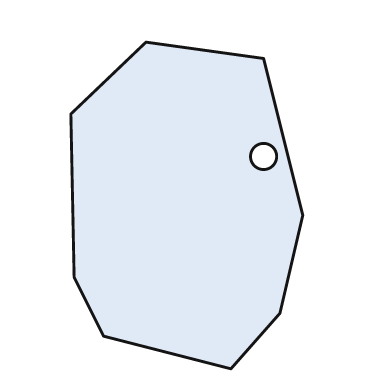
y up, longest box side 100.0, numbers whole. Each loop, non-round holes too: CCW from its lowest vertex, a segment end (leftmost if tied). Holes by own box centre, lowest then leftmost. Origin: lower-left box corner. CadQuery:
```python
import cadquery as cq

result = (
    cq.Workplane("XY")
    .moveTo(49.0, 0.0)
    .lineTo(64.0, 17.0)
    .lineTo(71.0, 47.0)
    .lineTo(59.0, 95.0)
    .lineTo(23.0, 100.0)
    .lineTo(0.0, 78.0)
    .lineTo(1.0, 28.0)
    .lineTo(10.0, 10.0)
    .close()
    .moveTo(59.0, 65.0)
    .circle(4.0)
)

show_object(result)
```